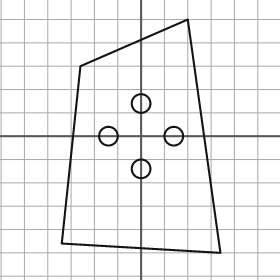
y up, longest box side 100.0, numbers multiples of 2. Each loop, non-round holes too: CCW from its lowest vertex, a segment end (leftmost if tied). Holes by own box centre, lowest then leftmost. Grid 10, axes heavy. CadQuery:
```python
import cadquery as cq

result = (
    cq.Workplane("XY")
    .moveTo(34.0, -50.0)
    .lineTo(20.0, 50.0)
    .lineTo(-26.0, 30.0)
    .lineTo(-34.0, -46.0)
    .close()
    .moveTo(0.0, -14.0)
    .circle(4.0)
    .moveTo(-14.0, 0.0)
    .circle(4.0)
    .moveTo(14.0, 0.0)
    .circle(4.0)
    .moveTo(0.0, 14.0)
    .circle(4.0)
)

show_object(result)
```